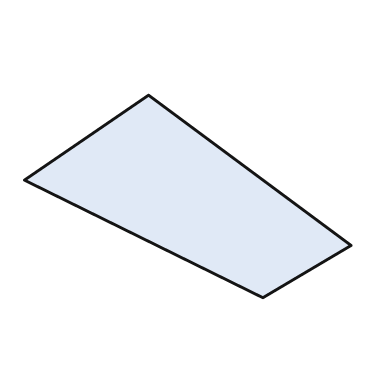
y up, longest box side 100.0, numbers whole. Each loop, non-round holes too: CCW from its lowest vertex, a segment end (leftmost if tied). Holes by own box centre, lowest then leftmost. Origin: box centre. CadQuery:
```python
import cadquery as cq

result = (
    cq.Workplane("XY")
    .moveTo(23.0, -31.0)
    .lineTo(50.0, -15.0)
    .lineTo(-12.0, 31.0)
    .lineTo(-50.0, 5.0)
    .close()
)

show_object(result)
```